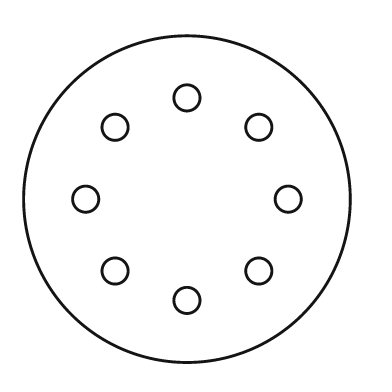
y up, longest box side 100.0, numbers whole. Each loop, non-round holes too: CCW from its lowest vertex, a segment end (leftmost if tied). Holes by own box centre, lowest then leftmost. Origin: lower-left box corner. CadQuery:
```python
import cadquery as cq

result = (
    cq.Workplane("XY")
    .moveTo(50.0, 50.0)
    .circle(50.0)
    .moveTo(50.0, 19.0)
    .circle(4.0)
    .moveTo(28.0, 28.0)
    .circle(4.0)
    .moveTo(72.0, 28.0)
    .circle(4.0)
    .moveTo(19.0, 50.0)
    .circle(4.0)
    .moveTo(81.0, 50.0)
    .circle(4.0)
    .moveTo(28.0, 72.0)
    .circle(4.0)
    .moveTo(72.0, 72.0)
    .circle(4.0)
    .moveTo(50.0, 81.0)
    .circle(4.0)
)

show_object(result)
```